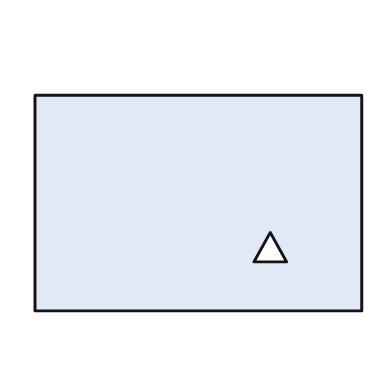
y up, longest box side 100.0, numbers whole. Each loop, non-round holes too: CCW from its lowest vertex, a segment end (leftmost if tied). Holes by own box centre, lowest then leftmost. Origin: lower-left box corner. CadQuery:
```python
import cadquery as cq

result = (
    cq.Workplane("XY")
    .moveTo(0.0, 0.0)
    .lineTo(100.0, 0.0)
    .lineTo(100.0, 66.0)
    .lineTo(0.0, 66.0)
    .close()
    .moveTo(67.0, 15.0)
    .lineTo(77.0, 15.0)
    .lineTo(72.0, 24.0)
    .close()
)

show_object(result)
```